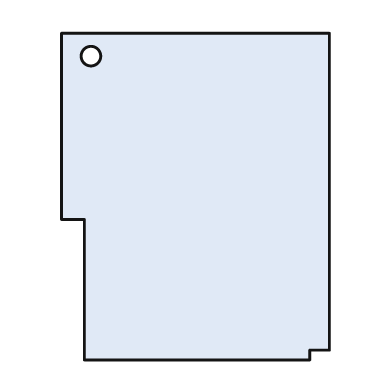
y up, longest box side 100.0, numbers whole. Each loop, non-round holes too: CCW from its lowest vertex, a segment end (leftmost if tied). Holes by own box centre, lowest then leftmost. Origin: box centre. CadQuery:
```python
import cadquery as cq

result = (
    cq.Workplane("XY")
    .moveTo(-34.0, -50.0)
    .lineTo(35.0, -50.0)
    .lineTo(35.0, -47.0)
    .lineTo(41.0, -47.0)
    .lineTo(41.0, 50.0)
    .lineTo(-41.0, 50.0)
    .lineTo(-41.0, -7.0)
    .lineTo(-34.0, -7.0)
    .close()
    .moveTo(-32.0, 43.0)
    .circle(3.0)
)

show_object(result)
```